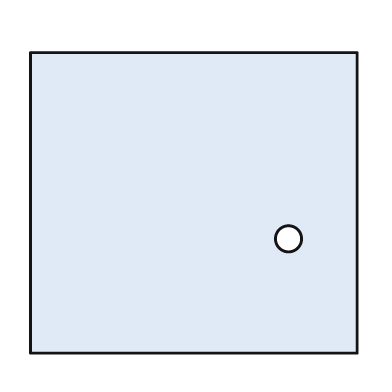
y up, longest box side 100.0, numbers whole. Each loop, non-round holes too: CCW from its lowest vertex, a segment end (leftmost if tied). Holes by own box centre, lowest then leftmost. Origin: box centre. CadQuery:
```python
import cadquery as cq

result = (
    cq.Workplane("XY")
    .moveTo(-50.0, -46.0)
    .lineTo(50.0, -46.0)
    .lineTo(50.0, 46.0)
    .lineTo(-50.0, 46.0)
    .close()
    .moveTo(29.0, -11.0)
    .circle(4.0)
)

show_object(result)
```